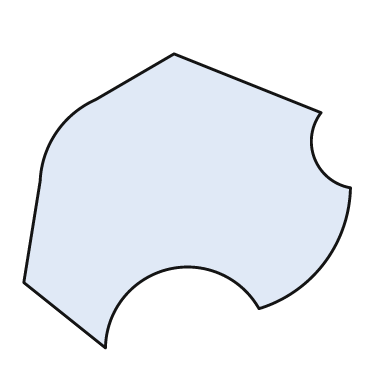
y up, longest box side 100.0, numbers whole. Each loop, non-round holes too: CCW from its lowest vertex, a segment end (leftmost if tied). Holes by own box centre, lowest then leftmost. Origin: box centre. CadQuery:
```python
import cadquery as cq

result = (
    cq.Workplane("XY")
    .moveTo(-25.0, -45.0)
    .threePointArc((-6.0, -21.0), (22.0, -33.0))
    .threePointArc((42.0, -19.0), (50.0, 4.0))
    .threePointArc((39.0, 13.0), (41.0, 27.0))
    .lineTo(-4.0, 45.0)
    .lineTo(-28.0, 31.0)
    .threePointArc((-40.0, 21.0), (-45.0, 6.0))
    .lineTo(-50.0, -25.0)
    .close()
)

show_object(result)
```